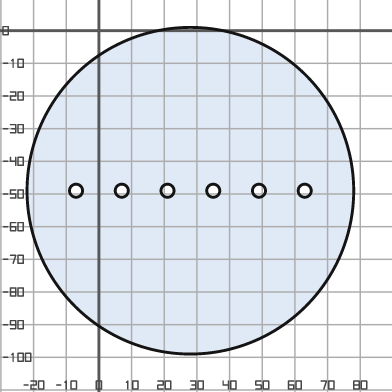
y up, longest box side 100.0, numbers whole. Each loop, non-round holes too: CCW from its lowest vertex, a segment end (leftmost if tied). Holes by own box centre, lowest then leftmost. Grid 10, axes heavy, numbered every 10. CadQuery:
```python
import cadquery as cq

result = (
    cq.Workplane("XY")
    .moveTo(28.0, -49.0)
    .circle(50.0)
    .moveTo(-7.0, -49.0)
    .circle(2.0)
    .moveTo(7.0, -49.0)
    .circle(2.0)
    .moveTo(21.0, -49.0)
    .circle(2.0)
    .moveTo(35.0, -49.0)
    .circle(2.0)
    .moveTo(49.0, -49.0)
    .circle(2.0)
    .moveTo(63.0, -49.0)
    .circle(2.0)
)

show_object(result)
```